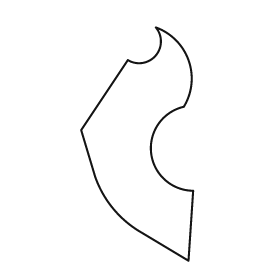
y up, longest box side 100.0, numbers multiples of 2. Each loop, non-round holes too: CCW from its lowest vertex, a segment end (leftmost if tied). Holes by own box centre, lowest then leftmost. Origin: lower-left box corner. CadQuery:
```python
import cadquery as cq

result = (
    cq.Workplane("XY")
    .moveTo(46.0, 0.0)
    .lineTo(48.0, 30.0)
    .threePointArc((30.0, 46.0), (44.0, 66.0))
    .threePointArc((46.0, 86.0), (32.0, 100.0))
    .threePointArc((32.0, 88.0), (20.0, 86.0))
    .lineTo(0.0, 56.0)
    .lineTo(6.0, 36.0)
    .threePointArc((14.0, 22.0), (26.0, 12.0))
    .close()
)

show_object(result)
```